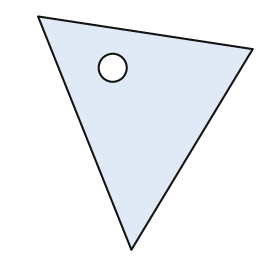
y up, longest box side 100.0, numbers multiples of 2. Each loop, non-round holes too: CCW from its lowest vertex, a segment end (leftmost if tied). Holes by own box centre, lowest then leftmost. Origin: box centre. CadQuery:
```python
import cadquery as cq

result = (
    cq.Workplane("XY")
    .moveTo(-6.0, -50.0)
    .lineTo(46.0, 36.0)
    .lineTo(-46.0, 50.0)
    .close()
    .moveTo(-14.0, 28.0)
    .circle(6.0)
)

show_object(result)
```